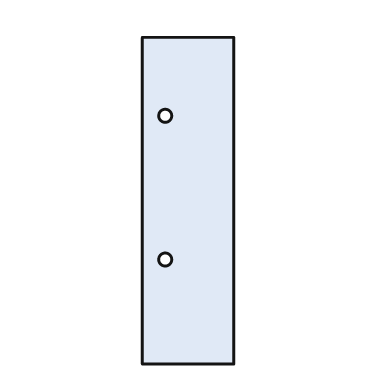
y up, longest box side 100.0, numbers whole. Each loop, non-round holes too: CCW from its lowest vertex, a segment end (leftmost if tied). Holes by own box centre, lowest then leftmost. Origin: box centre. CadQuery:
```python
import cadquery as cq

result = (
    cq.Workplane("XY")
    .moveTo(-14.0, -50.0)
    .lineTo(14.0, -50.0)
    .lineTo(14.0, 50.0)
    .lineTo(-14.0, 50.0)
    .close()
    .moveTo(-7.0, -18.0)
    .circle(2.0)
    .moveTo(-7.0, 26.0)
    .circle(2.0)
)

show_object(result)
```